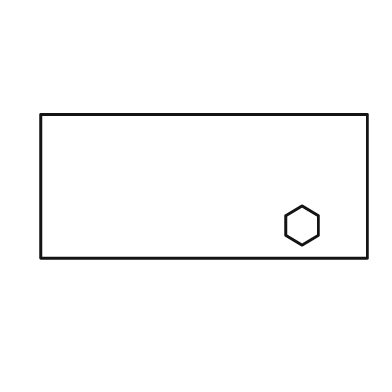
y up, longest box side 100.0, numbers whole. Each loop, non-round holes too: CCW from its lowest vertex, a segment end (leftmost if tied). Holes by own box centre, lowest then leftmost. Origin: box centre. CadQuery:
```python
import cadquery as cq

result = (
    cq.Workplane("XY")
    .moveTo(-50.0, -22.0)
    .lineTo(50.0, -22.0)
    .lineTo(50.0, 22.0)
    .lineTo(-50.0, 22.0)
    .close()
    .moveTo(30.0, -18.0)
    .lineTo(35.0, -15.0)
    .lineTo(35.0, -9.0)
    .lineTo(30.0, -6.0)
    .lineTo(25.0, -9.0)
    .lineTo(25.0, -15.0)
    .close()
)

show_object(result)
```